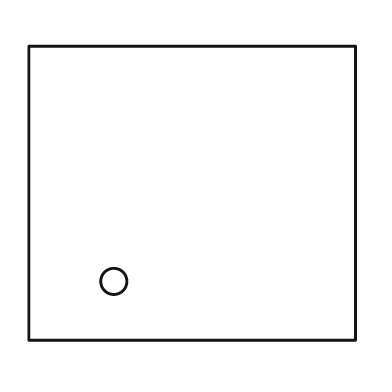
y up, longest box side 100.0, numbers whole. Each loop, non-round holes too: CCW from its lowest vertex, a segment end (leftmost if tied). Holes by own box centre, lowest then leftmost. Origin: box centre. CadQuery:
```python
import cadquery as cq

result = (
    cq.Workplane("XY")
    .moveTo(-50.0, -45.0)
    .lineTo(50.0, -45.0)
    .lineTo(50.0, 45.0)
    .lineTo(-50.0, 45.0)
    .close()
    .moveTo(-24.0, -27.0)
    .circle(4.0)
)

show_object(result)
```